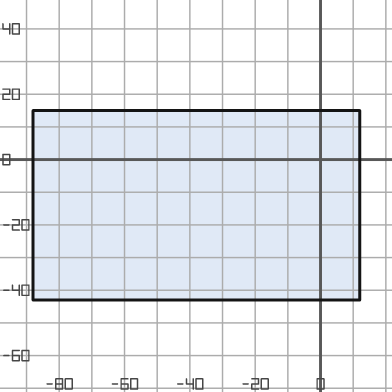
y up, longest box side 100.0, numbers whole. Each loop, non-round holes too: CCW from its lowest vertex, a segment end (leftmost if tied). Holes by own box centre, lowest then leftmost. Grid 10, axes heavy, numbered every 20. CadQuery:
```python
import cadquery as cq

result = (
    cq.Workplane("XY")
    .moveTo(-88.0, -43.0)
    .lineTo(12.0, -43.0)
    .lineTo(12.0, 15.0)
    .lineTo(-88.0, 15.0)
    .close()
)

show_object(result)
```